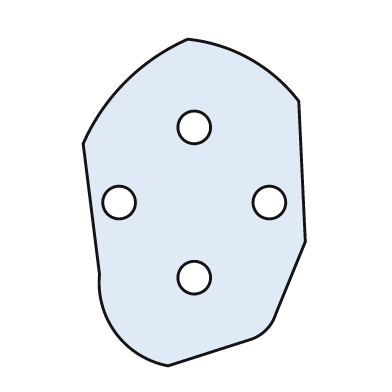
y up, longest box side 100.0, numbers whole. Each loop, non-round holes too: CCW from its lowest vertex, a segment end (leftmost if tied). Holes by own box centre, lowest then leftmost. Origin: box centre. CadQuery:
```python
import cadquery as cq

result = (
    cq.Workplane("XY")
    .moveTo(-8.0, -50.0)
    .lineTo(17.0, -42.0)
    .threePointArc((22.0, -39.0), (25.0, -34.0))
    .lineTo(34.0, -12.0)
    .lineTo(32.0, 31.0)
    .threePointArc((17.0, 44.0), (-2.0, 50.0))
    .threePointArc((-21.0, 37.0), (-34.0, 18.0))
    .lineTo(-29.0, -22.0)
    .threePointArc((-24.0, -40.0), (-8.0, -50.0))
    .close()
    .moveTo(0.0, -23.0)
    .circle(5.0)
    .moveTo(-23.0, 0.0)
    .circle(5.0)
    .moveTo(23.0, 0.0)
    .circle(5.0)
    .moveTo(0.0, 23.0)
    .circle(5.0)
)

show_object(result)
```